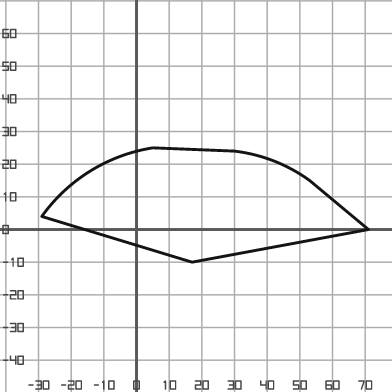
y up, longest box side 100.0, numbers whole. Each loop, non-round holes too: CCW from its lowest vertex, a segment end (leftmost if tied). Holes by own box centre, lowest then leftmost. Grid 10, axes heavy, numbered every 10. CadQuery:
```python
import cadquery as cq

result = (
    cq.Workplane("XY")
    .moveTo(17.0, -10.0)
    .lineTo(71.0, 0.0)
    .lineTo(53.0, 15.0)
    .threePointArc((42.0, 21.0), (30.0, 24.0))
    .lineTo(5.0, 25.0)
    .threePointArc((-14.0, 18.0), (-29.0, 4.0))
    .close()
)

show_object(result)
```